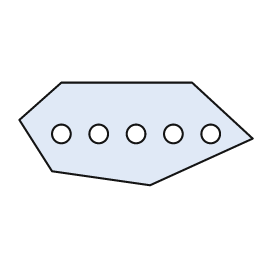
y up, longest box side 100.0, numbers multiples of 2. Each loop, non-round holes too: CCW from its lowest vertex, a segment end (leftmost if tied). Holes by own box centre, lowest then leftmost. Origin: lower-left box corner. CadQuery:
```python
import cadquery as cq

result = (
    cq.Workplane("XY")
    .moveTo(56.0, 0.0)
    .lineTo(100.0, 20.0)
    .lineTo(74.0, 44.0)
    .lineTo(18.0, 44.0)
    .lineTo(0.0, 28.0)
    .lineTo(14.0, 6.0)
    .close()
    .moveTo(18.0, 22.0)
    .circle(4.0)
    .moveTo(34.0, 22.0)
    .circle(4.0)
    .moveTo(50.0, 22.0)
    .circle(4.0)
    .moveTo(66.0, 22.0)
    .circle(4.0)
    .moveTo(82.0, 22.0)
    .circle(4.0)
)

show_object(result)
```